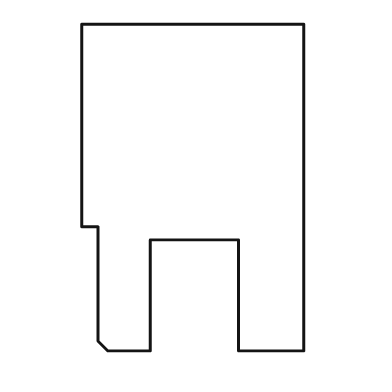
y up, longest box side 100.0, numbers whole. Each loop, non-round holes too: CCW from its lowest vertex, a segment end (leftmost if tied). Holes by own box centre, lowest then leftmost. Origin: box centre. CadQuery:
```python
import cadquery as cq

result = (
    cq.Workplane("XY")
    .moveTo(-26.0, -50.0)
    .lineTo(-13.0, -50.0)
    .lineTo(-13.0, -16.0)
    .lineTo(14.0, -16.0)
    .lineTo(14.0, -50.0)
    .lineTo(34.0, -50.0)
    .lineTo(34.0, 50.0)
    .lineTo(-34.0, 50.0)
    .lineTo(-34.0, -12.0)
    .lineTo(-29.0, -12.0)
    .lineTo(-29.0, -47.0)
    .close()
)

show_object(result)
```